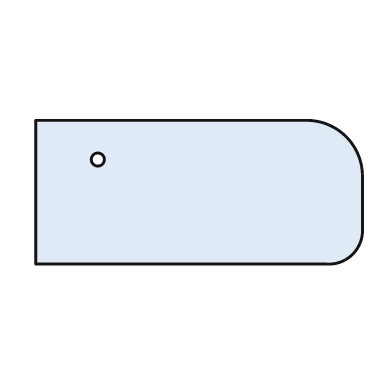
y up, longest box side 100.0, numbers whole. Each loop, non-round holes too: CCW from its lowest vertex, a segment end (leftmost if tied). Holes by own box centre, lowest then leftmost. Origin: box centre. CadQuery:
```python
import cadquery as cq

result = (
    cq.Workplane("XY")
    .moveTo(-50.0, -22.0)
    .lineTo(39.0, -22.0)
    .threePointArc((47.0, -19.0), (50.0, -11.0))
    .lineTo(50.0, 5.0)
    .threePointArc((45.0, 17.0), (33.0, 22.0))
    .lineTo(-50.0, 22.0)
    .close()
    .moveTo(-31.0, 10.0)
    .circle(2.0)
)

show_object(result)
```